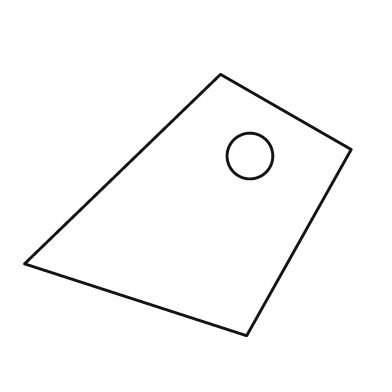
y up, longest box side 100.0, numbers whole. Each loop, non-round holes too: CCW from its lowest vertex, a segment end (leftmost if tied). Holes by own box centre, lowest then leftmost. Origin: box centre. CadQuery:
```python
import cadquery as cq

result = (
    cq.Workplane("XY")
    .moveTo(18.0, -40.0)
    .lineTo(50.0, 17.0)
    .lineTo(10.0, 40.0)
    .lineTo(-50.0, -18.0)
    .close()
    .moveTo(19.0, 15.0)
    .circle(7.0)
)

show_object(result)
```